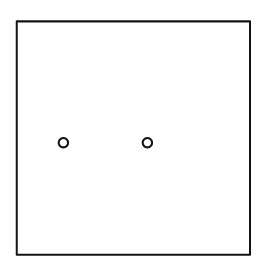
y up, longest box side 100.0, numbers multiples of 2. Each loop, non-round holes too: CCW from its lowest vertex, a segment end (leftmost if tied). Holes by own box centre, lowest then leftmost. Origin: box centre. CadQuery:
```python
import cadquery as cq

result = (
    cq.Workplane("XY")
    .moveTo(-50.0, -50.0)
    .lineTo(50.0, -50.0)
    .lineTo(50.0, 50.0)
    .lineTo(-50.0, 50.0)
    .close()
    .moveTo(-30.0, -2.0)
    .circle(2.0)
    .moveTo(6.0, -2.0)
    .circle(2.0)
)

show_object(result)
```